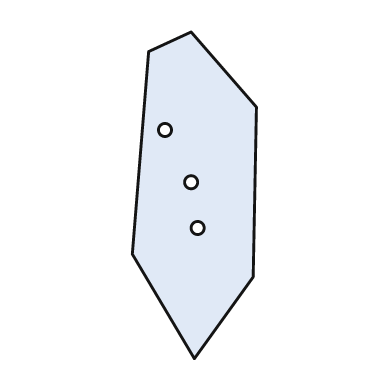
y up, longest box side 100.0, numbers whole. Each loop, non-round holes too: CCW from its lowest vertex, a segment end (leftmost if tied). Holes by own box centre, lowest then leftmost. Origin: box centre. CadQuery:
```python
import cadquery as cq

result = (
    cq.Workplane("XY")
    .moveTo(0.0, -50.0)
    .lineTo(18.0, -25.0)
    .lineTo(19.0, 27.0)
    .lineTo(-1.0, 50.0)
    .lineTo(-14.0, 44.0)
    .lineTo(-19.0, -18.0)
    .close()
    .moveTo(1.0, -10.0)
    .circle(2.0)
    .moveTo(-1.0, 4.0)
    .circle(2.0)
    .moveTo(-9.0, 20.0)
    .circle(2.0)
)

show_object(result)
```